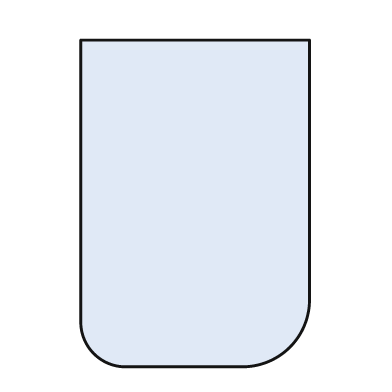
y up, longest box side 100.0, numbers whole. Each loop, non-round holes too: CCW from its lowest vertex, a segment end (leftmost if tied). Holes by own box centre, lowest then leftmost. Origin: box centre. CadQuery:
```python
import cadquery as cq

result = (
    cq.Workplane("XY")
    .moveTo(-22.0, -50.0)
    .lineTo(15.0, -50.0)
    .threePointArc((29.0, -44.0), (35.0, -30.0))
    .lineTo(35.0, 50.0)
    .lineTo(-35.0, 50.0)
    .lineTo(-35.0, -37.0)
    .threePointArc((-31.0, -46.0), (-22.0, -50.0))
    .close()
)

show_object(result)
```